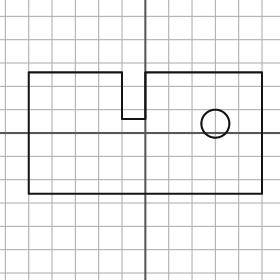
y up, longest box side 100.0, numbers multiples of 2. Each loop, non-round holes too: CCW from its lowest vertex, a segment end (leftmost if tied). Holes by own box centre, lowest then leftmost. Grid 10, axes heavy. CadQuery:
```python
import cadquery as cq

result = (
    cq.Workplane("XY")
    .moveTo(-50.0, -26.0)
    .lineTo(50.0, -26.0)
    .lineTo(50.0, 26.0)
    .lineTo(0.0, 26.0)
    .lineTo(0.0, 6.0)
    .lineTo(-10.0, 6.0)
    .lineTo(-10.0, 26.0)
    .lineTo(-50.0, 26.0)
    .close()
    .moveTo(30.0, 4.0)
    .circle(6.0)
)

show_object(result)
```